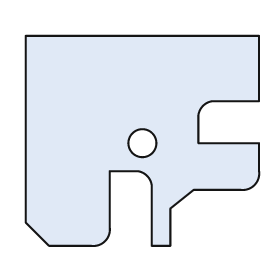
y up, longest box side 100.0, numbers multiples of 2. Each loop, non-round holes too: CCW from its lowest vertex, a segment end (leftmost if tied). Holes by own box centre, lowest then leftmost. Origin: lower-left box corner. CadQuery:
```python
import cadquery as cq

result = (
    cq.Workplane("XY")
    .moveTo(10.0, 0.0)
    .lineTo(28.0, 0.0)
    .threePointArc((34.0, 2.0), (36.0, 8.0))
    .lineTo(36.0, 32.0)
    .lineTo(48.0, 32.0)
    .threePointArc((52.0, 30.0), (54.0, 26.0))
    .lineTo(54.0, 0.0)
    .lineTo(62.0, 0.0)
    .lineTo(62.0, 16.0)
    .lineTo(72.0, 24.0)
    .lineTo(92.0, 24.0)
    .threePointArc((98.0, 26.0), (100.0, 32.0))
    .lineTo(100.0, 44.0)
    .lineTo(74.0, 44.0)
    .lineTo(74.0, 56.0)
    .threePointArc((76.0, 60.0), (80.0, 62.0))
    .lineTo(100.0, 62.0)
    .lineTo(100.0, 90.0)
    .lineTo(0.0, 90.0)
    .lineTo(0.0, 10.0)
    .close()
    .moveTo(50.0, 44.0)
    .circle(6.0)
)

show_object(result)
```